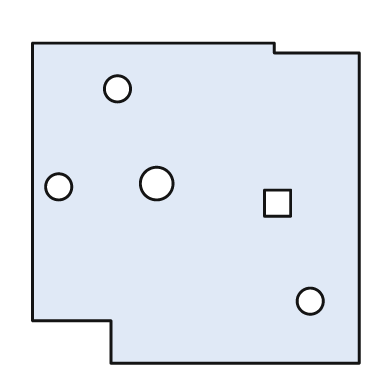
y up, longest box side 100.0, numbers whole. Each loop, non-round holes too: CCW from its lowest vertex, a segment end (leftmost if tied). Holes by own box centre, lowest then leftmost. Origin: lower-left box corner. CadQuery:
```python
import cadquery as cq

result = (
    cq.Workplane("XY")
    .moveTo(24.0, 0.0)
    .lineTo(100.0, 0.0)
    .lineTo(100.0, 95.0)
    .lineTo(74.0, 95.0)
    .lineTo(74.0, 98.0)
    .lineTo(0.0, 98.0)
    .lineTo(0.0, 13.0)
    .lineTo(24.0, 13.0)
    .close()
    .moveTo(85.0, 19.0)
    .circle(4.0)
    .moveTo(71.0, 45.0)
    .lineTo(79.0, 45.0)
    .lineTo(79.0, 53.0)
    .lineTo(71.0, 53.0)
    .close()
    .moveTo(8.0, 54.0)
    .circle(4.0)
    .moveTo(38.0, 55.0)
    .circle(5.0)
    .moveTo(26.0, 84.0)
    .circle(4.0)
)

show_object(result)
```